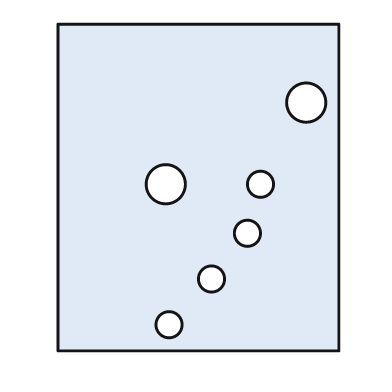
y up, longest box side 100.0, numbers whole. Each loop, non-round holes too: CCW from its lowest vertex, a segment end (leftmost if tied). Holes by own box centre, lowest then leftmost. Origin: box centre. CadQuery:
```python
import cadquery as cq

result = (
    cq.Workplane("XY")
    .moveTo(-43.0, -50.0)
    .lineTo(43.0, -50.0)
    .lineTo(43.0, 50.0)
    .lineTo(-43.0, 50.0)
    .close()
    .moveTo(-9.0, -42.0)
    .circle(4.0)
    .moveTo(4.0, -28.0)
    .circle(4.0)
    .moveTo(15.0, -14.0)
    .circle(4.0)
    .moveTo(-10.0, 1.0)
    .circle(6.0)
    .moveTo(19.0, 1.0)
    .circle(4.0)
    .moveTo(33.0, 26.0)
    .circle(6.0)
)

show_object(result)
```